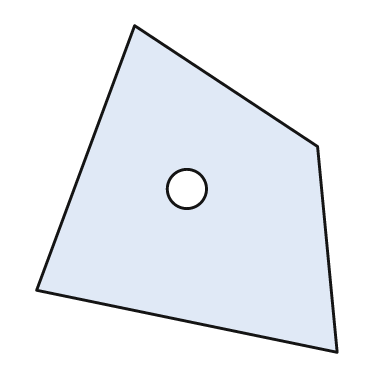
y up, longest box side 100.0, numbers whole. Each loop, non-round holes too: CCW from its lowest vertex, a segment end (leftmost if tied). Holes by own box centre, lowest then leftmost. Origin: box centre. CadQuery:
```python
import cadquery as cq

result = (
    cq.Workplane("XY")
    .moveTo(46.0, -50.0)
    .lineTo(40.0, 13.0)
    .lineTo(-16.0, 50.0)
    .lineTo(-46.0, -31.0)
    .close()
    .moveTo(0.0, 0.0)
    .circle(6.0)
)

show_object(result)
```